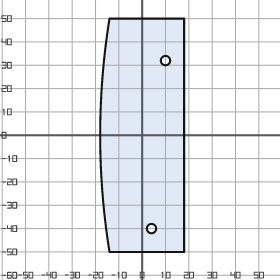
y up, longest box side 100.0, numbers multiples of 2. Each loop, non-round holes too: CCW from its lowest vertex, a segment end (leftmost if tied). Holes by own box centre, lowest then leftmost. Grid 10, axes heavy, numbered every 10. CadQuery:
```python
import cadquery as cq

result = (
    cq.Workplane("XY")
    .moveTo(-14.0, -50.0)
    .lineTo(18.0, -50.0)
    .lineTo(18.0, 50.0)
    .lineTo(-14.0, 50.0)
    .threePointArc((-18.0, 0.0), (-14.0, -50.0))
    .close()
    .moveTo(4.0, -40.0)
    .circle(2.0)
    .moveTo(10.0, 32.0)
    .circle(2.0)
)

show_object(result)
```